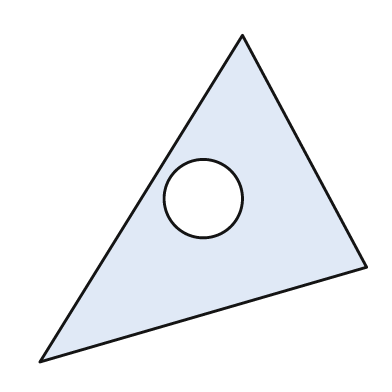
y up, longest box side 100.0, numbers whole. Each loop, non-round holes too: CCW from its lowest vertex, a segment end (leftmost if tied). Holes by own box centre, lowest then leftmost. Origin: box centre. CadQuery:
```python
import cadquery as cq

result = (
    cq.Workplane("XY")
    .moveTo(-50.0, -50.0)
    .lineTo(50.0, -21.0)
    .lineTo(12.0, 50.0)
    .close()
    .moveTo(0.0, 0.0)
    .circle(12.0)
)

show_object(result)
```